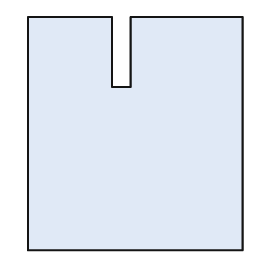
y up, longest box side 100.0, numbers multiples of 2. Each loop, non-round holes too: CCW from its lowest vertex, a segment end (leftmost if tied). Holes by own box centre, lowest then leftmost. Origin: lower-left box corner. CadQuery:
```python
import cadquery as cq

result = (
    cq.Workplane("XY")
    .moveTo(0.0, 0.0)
    .lineTo(92.0, 0.0)
    .lineTo(92.0, 100.0)
    .lineTo(44.0, 100.0)
    .lineTo(44.0, 70.0)
    .lineTo(36.0, 70.0)
    .lineTo(36.0, 100.0)
    .lineTo(0.0, 100.0)
    .close()
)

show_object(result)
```